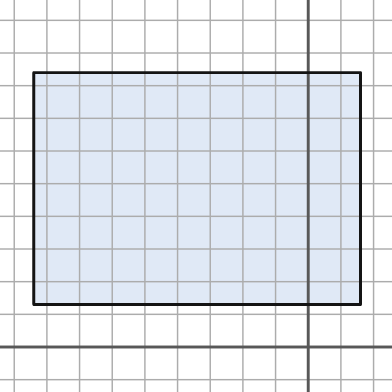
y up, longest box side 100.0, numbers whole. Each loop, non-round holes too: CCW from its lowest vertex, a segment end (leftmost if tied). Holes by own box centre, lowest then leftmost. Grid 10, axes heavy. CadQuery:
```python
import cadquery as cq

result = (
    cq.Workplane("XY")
    .moveTo(-84.0, 13.0)
    .lineTo(16.0, 13.0)
    .lineTo(16.0, 84.0)
    .lineTo(-84.0, 84.0)
    .close()
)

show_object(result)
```